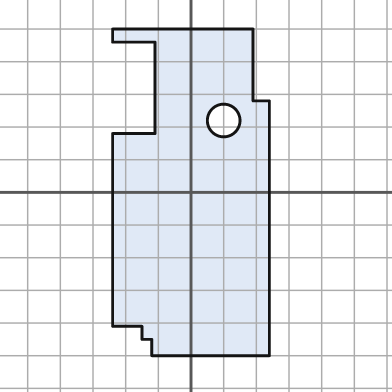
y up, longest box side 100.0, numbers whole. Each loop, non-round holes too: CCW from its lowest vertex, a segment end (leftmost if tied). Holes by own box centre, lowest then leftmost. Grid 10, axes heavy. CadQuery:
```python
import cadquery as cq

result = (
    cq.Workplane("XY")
    .moveTo(-12.0, -50.0)
    .lineTo(24.0, -50.0)
    .lineTo(24.0, 28.0)
    .lineTo(19.0, 28.0)
    .lineTo(19.0, 50.0)
    .lineTo(-24.0, 50.0)
    .lineTo(-24.0, 46.0)
    .lineTo(-11.0, 46.0)
    .lineTo(-11.0, 18.0)
    .lineTo(-24.0, 18.0)
    .lineTo(-24.0, -41.0)
    .lineTo(-15.0, -41.0)
    .lineTo(-15.0, -45.0)
    .lineTo(-12.0, -45.0)
    .close()
    .moveTo(10.0, 22.0)
    .circle(5.0)
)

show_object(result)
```